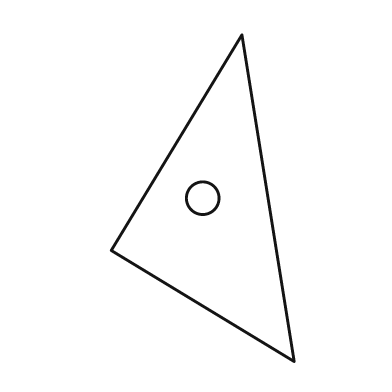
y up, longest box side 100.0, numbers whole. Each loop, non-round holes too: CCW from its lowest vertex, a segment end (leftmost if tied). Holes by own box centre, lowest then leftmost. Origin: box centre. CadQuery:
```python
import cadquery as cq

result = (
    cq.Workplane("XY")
    .moveTo(28.0, -50.0)
    .lineTo(12.0, 50.0)
    .lineTo(-28.0, -16.0)
    .close()
    .moveTo(0.0, 0.0)
    .circle(5.0)
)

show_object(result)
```